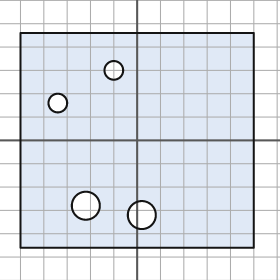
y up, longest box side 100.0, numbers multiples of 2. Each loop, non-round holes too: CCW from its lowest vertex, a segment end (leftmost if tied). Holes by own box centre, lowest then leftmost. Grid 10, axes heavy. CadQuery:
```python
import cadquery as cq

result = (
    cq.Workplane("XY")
    .moveTo(-50.0, -46.0)
    .lineTo(50.0, -46.0)
    .lineTo(50.0, 46.0)
    .lineTo(-50.0, 46.0)
    .close()
    .moveTo(2.0, -32.0)
    .circle(6.0)
    .moveTo(-22.0, -28.0)
    .circle(6.0)
    .moveTo(-34.0, 16.0)
    .circle(4.0)
    .moveTo(-10.0, 30.0)
    .circle(4.0)
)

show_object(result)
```